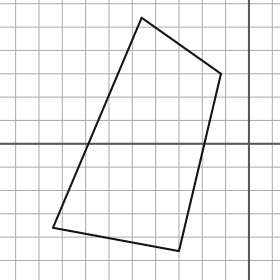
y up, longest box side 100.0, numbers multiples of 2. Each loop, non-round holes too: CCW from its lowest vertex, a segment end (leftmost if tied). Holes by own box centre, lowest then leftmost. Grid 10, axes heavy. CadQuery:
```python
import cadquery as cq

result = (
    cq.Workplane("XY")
    .moveTo(-30.0, -46.0)
    .lineTo(-12.0, 30.0)
    .lineTo(-46.0, 54.0)
    .lineTo(-84.0, -36.0)
    .close()
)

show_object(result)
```